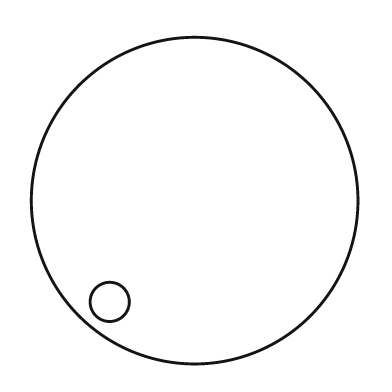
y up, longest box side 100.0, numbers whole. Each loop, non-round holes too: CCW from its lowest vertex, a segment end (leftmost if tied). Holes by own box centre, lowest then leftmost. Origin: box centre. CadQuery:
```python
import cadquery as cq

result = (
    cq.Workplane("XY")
    .moveTo(0.0, 0.0)
    .circle(50.0)
    .moveTo(-26.0, -31.0)
    .circle(6.0)
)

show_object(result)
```